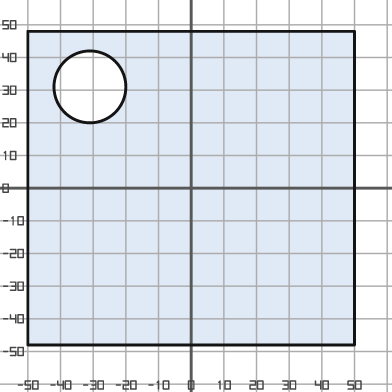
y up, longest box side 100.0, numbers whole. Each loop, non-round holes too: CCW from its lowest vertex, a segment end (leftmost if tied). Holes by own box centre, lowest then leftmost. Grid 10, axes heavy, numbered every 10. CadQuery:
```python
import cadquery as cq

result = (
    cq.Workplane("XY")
    .moveTo(-50.0, -48.0)
    .lineTo(50.0, -48.0)
    .lineTo(50.0, 48.0)
    .lineTo(-50.0, 48.0)
    .close()
    .moveTo(-31.0, 31.0)
    .circle(11.0)
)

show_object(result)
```